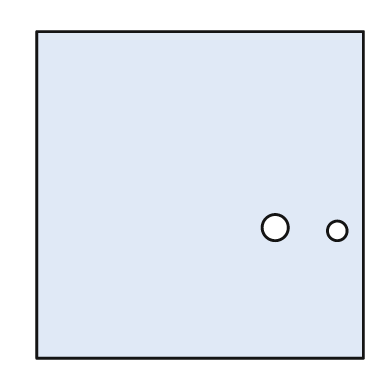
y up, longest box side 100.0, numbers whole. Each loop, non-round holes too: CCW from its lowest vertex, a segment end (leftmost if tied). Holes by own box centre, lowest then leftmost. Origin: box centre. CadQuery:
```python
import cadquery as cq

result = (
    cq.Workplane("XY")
    .moveTo(-50.0, -50.0)
    .lineTo(50.0, -50.0)
    .lineTo(50.0, 50.0)
    .lineTo(-50.0, 50.0)
    .close()
    .moveTo(42.0, -11.0)
    .circle(3.0)
    .moveTo(23.0, -10.0)
    .circle(4.0)
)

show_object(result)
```